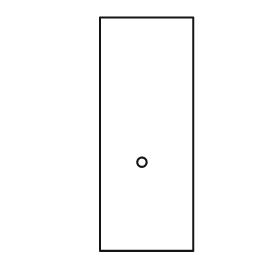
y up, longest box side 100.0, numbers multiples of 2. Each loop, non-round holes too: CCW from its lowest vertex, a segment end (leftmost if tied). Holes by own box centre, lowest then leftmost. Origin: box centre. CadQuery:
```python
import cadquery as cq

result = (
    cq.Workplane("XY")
    .moveTo(-20.0, -50.0)
    .lineTo(20.0, -50.0)
    .lineTo(20.0, 50.0)
    .lineTo(-20.0, 50.0)
    .close()
    .moveTo(-2.0, -12.0)
    .circle(2.0)
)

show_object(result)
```